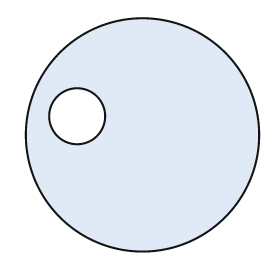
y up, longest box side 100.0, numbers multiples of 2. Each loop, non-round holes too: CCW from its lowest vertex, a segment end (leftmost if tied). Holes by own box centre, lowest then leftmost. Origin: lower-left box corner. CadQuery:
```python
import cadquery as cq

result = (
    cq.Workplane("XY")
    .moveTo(50.0, 50.0)
    .circle(50.0)
    .moveTo(22.0, 58.0)
    .circle(12.0)
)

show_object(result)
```